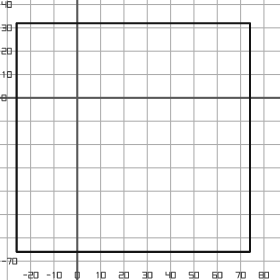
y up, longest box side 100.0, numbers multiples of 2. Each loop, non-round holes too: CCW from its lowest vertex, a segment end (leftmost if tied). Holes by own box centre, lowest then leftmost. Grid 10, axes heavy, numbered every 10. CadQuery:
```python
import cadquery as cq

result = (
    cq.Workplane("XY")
    .moveTo(-26.0, -66.0)
    .lineTo(74.0, -66.0)
    .lineTo(74.0, 32.0)
    .lineTo(-26.0, 32.0)
    .close()
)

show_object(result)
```